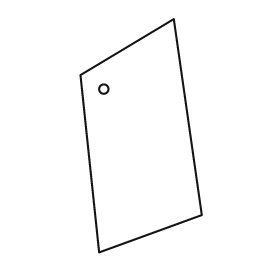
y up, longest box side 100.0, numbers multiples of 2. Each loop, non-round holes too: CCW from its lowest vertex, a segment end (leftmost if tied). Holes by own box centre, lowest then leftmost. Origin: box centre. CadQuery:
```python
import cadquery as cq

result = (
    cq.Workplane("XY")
    .moveTo(-18.0, -50.0)
    .lineTo(26.0, -34.0)
    .lineTo(14.0, 50.0)
    .lineTo(-26.0, 26.0)
    .close()
    .moveTo(-16.0, 20.0)
    .circle(2.0)
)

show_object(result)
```